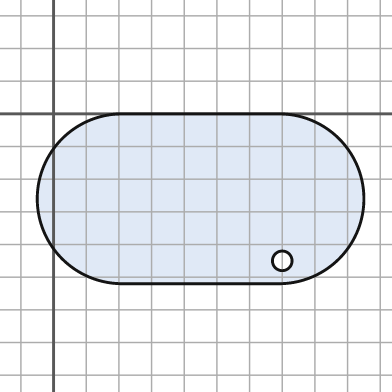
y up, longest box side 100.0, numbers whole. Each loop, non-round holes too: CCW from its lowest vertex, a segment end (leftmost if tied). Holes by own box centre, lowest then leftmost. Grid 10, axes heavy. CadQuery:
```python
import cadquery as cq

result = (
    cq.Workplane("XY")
    .moveTo(21.0, -52.0)
    .lineTo(69.0, -52.0)
    .threePointArc((95.0, -26.0), (69.0, 0.0))
    .lineTo(21.0, 0.0)
    .threePointArc((-5.0, -26.0), (21.0, -52.0))
    .close()
    .moveTo(70.0, -45.0)
    .circle(3.0)
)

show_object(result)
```